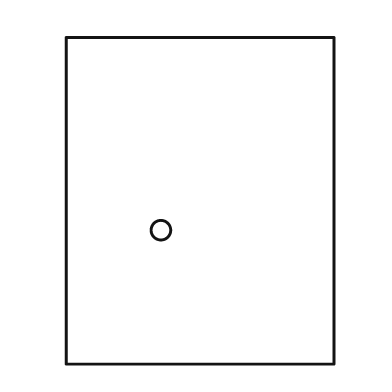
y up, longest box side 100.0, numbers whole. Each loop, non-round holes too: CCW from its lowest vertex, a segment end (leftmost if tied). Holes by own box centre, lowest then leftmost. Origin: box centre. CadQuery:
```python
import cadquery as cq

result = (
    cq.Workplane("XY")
    .moveTo(-41.0, -50.0)
    .lineTo(41.0, -50.0)
    .lineTo(41.0, 50.0)
    .lineTo(-41.0, 50.0)
    .close()
    .moveTo(-12.0, -9.0)
    .circle(3.0)
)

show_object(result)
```